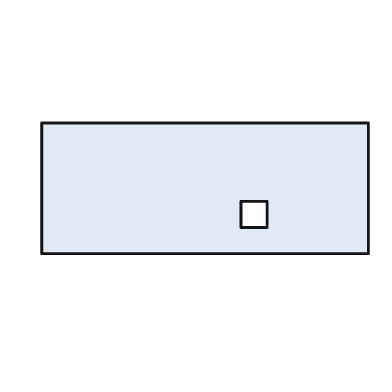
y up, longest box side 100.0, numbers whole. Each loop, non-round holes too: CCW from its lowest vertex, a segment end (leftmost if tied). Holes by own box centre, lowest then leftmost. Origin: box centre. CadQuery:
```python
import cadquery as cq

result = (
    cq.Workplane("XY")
    .moveTo(-50.0, -20.0)
    .lineTo(50.0, -20.0)
    .lineTo(50.0, 20.0)
    .lineTo(-50.0, 20.0)
    .close()
    .moveTo(11.0, -12.0)
    .lineTo(19.0, -12.0)
    .lineTo(19.0, -4.0)
    .lineTo(11.0, -4.0)
    .close()
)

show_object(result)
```